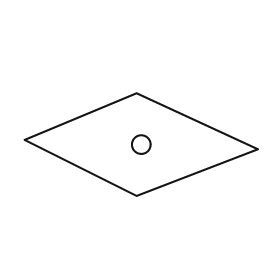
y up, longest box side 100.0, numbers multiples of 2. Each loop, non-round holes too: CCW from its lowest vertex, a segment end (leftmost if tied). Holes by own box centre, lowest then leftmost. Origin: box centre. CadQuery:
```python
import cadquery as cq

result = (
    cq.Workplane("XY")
    .moveTo(-2.0, -22.0)
    .lineTo(50.0, -2.0)
    .lineTo(-2.0, 22.0)
    .lineTo(-50.0, 2.0)
    .close()
    .moveTo(0.0, 0.0)
    .circle(4.0)
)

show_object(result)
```